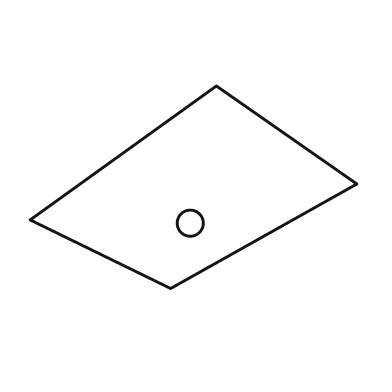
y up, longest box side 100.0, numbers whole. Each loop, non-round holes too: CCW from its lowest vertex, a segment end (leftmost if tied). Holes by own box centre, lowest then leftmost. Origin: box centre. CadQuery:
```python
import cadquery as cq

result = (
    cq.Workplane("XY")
    .moveTo(-7.0, -31.0)
    .lineTo(50.0, 1.0)
    .lineTo(7.0, 31.0)
    .lineTo(-50.0, -10.0)
    .close()
    .moveTo(-1.0, -11.0)
    .circle(4.0)
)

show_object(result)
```